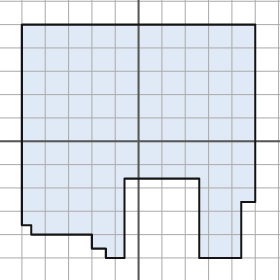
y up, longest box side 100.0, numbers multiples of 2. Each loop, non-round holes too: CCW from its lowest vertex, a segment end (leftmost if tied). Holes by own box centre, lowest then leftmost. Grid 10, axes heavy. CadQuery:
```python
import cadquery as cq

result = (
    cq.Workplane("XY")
    .moveTo(-14.0, -50.0)
    .lineTo(-6.0, -50.0)
    .lineTo(-6.0, -16.0)
    .lineTo(26.0, -16.0)
    .lineTo(26.0, -50.0)
    .lineTo(44.0, -50.0)
    .lineTo(44.0, -26.0)
    .lineTo(50.0, -26.0)
    .lineTo(50.0, 50.0)
    .lineTo(-50.0, 50.0)
    .lineTo(-50.0, -36.0)
    .lineTo(-46.0, -36.0)
    .lineTo(-46.0, -40.0)
    .lineTo(-20.0, -40.0)
    .lineTo(-20.0, -46.0)
    .lineTo(-14.0, -46.0)
    .close()
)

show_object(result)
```